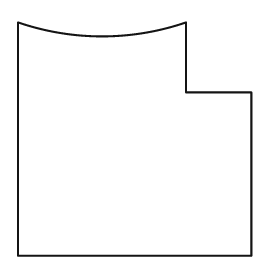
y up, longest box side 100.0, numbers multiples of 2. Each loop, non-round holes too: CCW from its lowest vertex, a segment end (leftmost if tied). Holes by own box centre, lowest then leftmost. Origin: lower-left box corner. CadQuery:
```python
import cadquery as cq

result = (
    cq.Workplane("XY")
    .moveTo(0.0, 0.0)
    .lineTo(100.0, 0.0)
    .lineTo(100.0, 70.0)
    .lineTo(72.0, 70.0)
    .lineTo(72.0, 100.0)
    .threePointArc((36.0, 94.0), (0.0, 100.0))
    .close()
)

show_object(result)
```